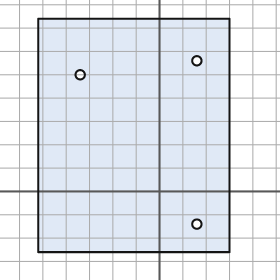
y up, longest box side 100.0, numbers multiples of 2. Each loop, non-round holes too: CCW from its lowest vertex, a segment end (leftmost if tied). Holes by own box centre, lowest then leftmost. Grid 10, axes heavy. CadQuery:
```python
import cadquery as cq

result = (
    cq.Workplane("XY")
    .moveTo(-52.0, -26.0)
    .lineTo(30.0, -26.0)
    .lineTo(30.0, 74.0)
    .lineTo(-52.0, 74.0)
    .close()
    .moveTo(16.0, -14.0)
    .circle(2.0)
    .moveTo(-34.0, 50.0)
    .circle(2.0)
    .moveTo(16.0, 56.0)
    .circle(2.0)
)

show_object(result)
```